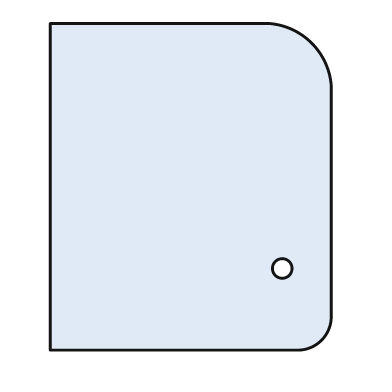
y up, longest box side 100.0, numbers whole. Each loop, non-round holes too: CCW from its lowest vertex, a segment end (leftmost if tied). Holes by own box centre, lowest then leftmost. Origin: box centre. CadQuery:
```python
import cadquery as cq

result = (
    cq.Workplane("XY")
    .moveTo(-43.0, -50.0)
    .lineTo(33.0, -50.0)
    .threePointArc((40.0, -47.0), (43.0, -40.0))
    .lineTo(43.0, 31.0)
    .threePointArc((37.0, 44.0), (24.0, 50.0))
    .lineTo(-43.0, 50.0)
    .close()
    .moveTo(28.0, -25.0)
    .circle(3.0)
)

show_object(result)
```